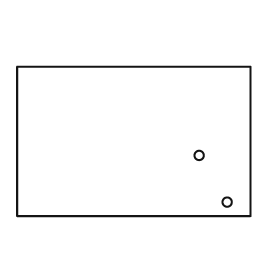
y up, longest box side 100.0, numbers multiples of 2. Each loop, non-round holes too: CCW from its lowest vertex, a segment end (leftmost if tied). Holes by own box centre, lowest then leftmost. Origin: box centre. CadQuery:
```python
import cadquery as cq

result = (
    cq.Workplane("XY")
    .moveTo(-50.0, -32.0)
    .lineTo(50.0, -32.0)
    .lineTo(50.0, 32.0)
    .lineTo(-50.0, 32.0)
    .close()
    .moveTo(40.0, -26.0)
    .circle(2.0)
    .moveTo(28.0, -6.0)
    .circle(2.0)
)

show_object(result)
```